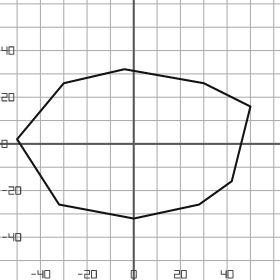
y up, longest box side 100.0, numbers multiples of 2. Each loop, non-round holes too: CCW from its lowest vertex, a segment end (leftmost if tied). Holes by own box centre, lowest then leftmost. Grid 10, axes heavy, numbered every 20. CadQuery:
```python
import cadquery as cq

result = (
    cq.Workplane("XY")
    .moveTo(0.0, -32.0)
    .lineTo(28.0, -26.0)
    .lineTo(42.0, -16.0)
    .lineTo(50.0, 16.0)
    .lineTo(30.0, 26.0)
    .lineTo(-4.0, 32.0)
    .lineTo(-30.0, 26.0)
    .lineTo(-50.0, 2.0)
    .lineTo(-32.0, -26.0)
    .close()
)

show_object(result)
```